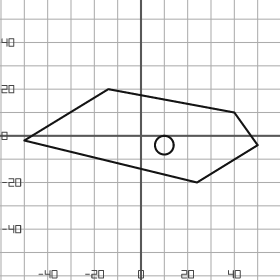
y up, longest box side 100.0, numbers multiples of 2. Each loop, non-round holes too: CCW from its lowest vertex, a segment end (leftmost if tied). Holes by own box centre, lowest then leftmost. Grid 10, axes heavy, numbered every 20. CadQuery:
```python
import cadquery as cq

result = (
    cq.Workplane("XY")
    .moveTo(24.0, -20.0)
    .lineTo(50.0, -4.0)
    .lineTo(40.0, 10.0)
    .lineTo(-14.0, 20.0)
    .lineTo(-50.0, -2.0)
    .close()
    .moveTo(10.0, -4.0)
    .circle(4.0)
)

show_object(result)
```